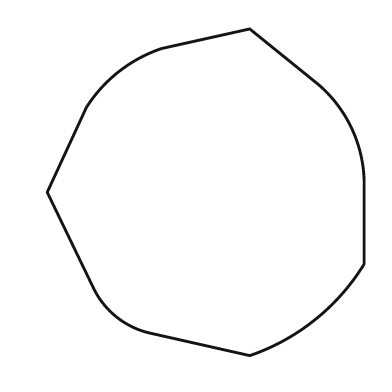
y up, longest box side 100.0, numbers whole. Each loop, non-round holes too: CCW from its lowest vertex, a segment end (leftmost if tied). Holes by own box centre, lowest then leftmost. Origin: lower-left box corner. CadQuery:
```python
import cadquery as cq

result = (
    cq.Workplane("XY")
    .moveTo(62.0, 0.0)
    .threePointArc((82.0, 11.0), (97.0, 28.0))
    .lineTo(97.0, 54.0)
    .threePointArc((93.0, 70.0), (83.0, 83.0))
    .lineTo(62.0, 100.0)
    .lineTo(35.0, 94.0)
    .threePointArc((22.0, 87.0), (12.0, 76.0))
    .lineTo(0.0, 50.0)
    .lineTo(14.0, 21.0)
    .threePointArc((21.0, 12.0), (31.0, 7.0))
    .close()
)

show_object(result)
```